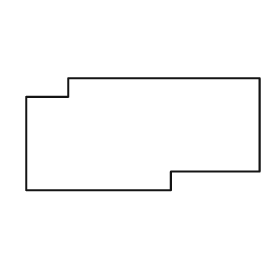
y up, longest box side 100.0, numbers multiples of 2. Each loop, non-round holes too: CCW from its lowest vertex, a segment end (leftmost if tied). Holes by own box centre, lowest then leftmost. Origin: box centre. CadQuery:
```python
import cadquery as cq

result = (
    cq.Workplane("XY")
    .moveTo(-50.0, -24.0)
    .lineTo(12.0, -24.0)
    .lineTo(12.0, -16.0)
    .lineTo(50.0, -16.0)
    .lineTo(50.0, 24.0)
    .lineTo(-32.0, 24.0)
    .lineTo(-32.0, 16.0)
    .lineTo(-50.0, 16.0)
    .close()
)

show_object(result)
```